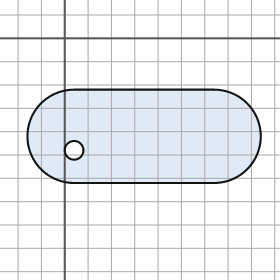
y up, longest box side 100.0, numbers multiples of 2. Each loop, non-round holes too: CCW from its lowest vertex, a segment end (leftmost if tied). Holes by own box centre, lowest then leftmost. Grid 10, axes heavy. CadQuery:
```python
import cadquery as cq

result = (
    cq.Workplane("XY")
    .moveTo(4.0, -62.0)
    .lineTo(64.0, -62.0)
    .threePointArc((84.0, -42.0), (64.0, -22.0))
    .lineTo(4.0, -22.0)
    .threePointArc((-16.0, -42.0), (4.0, -62.0))
    .close()
    .moveTo(4.0, -48.0)
    .circle(4.0)
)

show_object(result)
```